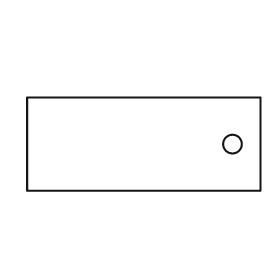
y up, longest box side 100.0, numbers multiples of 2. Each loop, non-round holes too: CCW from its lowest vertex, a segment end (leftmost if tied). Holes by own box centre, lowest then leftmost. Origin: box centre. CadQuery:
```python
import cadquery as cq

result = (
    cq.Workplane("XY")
    .moveTo(-50.0, -20.0)
    .lineTo(50.0, -20.0)
    .lineTo(50.0, 20.0)
    .lineTo(-50.0, 20.0)
    .close()
    .moveTo(38.0, 0.0)
    .circle(4.0)
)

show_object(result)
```